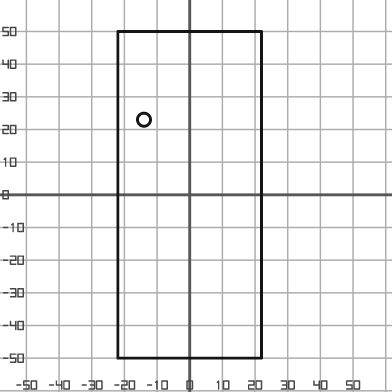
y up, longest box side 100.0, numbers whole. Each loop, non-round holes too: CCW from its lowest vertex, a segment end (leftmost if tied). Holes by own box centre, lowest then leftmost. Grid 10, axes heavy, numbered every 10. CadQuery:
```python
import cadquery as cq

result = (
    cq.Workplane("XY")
    .moveTo(-22.0, -50.0)
    .lineTo(22.0, -50.0)
    .lineTo(22.0, 50.0)
    .lineTo(-22.0, 50.0)
    .close()
    .moveTo(-14.0, 23.0)
    .circle(2.0)
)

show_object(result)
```